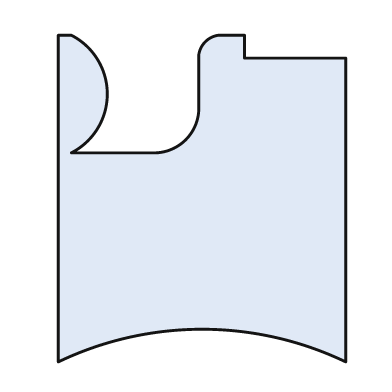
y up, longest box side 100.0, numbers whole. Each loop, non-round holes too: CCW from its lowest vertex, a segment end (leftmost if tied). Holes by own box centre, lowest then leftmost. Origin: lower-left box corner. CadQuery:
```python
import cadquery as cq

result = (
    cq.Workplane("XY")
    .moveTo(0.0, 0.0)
    .threePointArc((44.0, 10.0), (88.0, 0.0))
    .lineTo(88.0, 93.0)
    .lineTo(57.0, 93.0)
    .lineTo(57.0, 100.0)
    .lineTo(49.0, 100.0)
    .threePointArc((45.0, 98.0), (43.0, 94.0))
    .lineTo(43.0, 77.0)
    .threePointArc((39.0, 68.0), (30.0, 64.0))
    .lineTo(4.0, 64.0)
    .threePointArc((15.0, 82.0), (4.0, 100.0))
    .lineTo(0.0, 100.0)
    .close()
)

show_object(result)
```